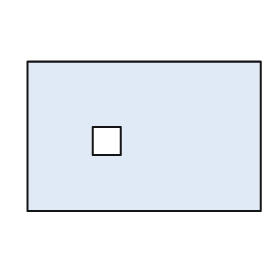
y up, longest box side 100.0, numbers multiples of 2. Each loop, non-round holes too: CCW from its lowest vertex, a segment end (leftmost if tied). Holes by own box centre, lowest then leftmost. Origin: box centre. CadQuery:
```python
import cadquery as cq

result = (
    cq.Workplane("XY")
    .moveTo(-50.0, -32.0)
    .lineTo(50.0, -32.0)
    .lineTo(50.0, 32.0)
    .lineTo(-50.0, 32.0)
    .close()
    .moveTo(-22.0, -8.0)
    .lineTo(-10.0, -8.0)
    .lineTo(-10.0, 4.0)
    .lineTo(-22.0, 4.0)
    .close()
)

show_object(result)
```